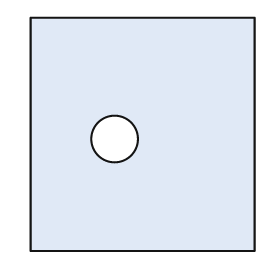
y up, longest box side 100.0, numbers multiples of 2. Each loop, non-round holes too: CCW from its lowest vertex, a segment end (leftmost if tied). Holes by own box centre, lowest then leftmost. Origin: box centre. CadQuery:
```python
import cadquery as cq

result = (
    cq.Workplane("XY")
    .moveTo(-48.0, -50.0)
    .lineTo(48.0, -50.0)
    .lineTo(48.0, 50.0)
    .lineTo(-48.0, 50.0)
    .close()
    .moveTo(-12.0, -2.0)
    .circle(10.0)
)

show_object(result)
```